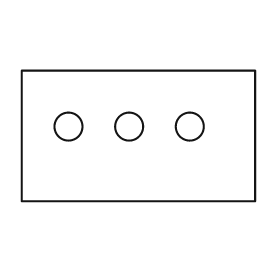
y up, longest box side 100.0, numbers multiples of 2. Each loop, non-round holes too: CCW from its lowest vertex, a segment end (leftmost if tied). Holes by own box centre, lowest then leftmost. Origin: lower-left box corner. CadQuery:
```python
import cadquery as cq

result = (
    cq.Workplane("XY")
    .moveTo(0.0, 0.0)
    .lineTo(100.0, 0.0)
    .lineTo(100.0, 56.0)
    .lineTo(0.0, 56.0)
    .close()
    .moveTo(20.0, 32.0)
    .circle(6.0)
    .moveTo(46.0, 32.0)
    .circle(6.0)
    .moveTo(72.0, 32.0)
    .circle(6.0)
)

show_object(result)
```